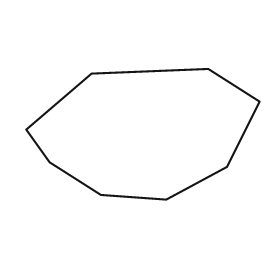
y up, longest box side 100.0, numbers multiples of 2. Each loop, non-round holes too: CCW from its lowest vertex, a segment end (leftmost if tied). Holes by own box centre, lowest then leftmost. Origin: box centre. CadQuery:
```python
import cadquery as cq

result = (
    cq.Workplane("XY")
    .moveTo(10.0, -28.0)
    .lineTo(36.0, -14.0)
    .lineTo(50.0, 14.0)
    .lineTo(28.0, 28.0)
    .lineTo(-22.0, 26.0)
    .lineTo(-50.0, 2.0)
    .lineTo(-40.0, -12.0)
    .lineTo(-18.0, -26.0)
    .close()
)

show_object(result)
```